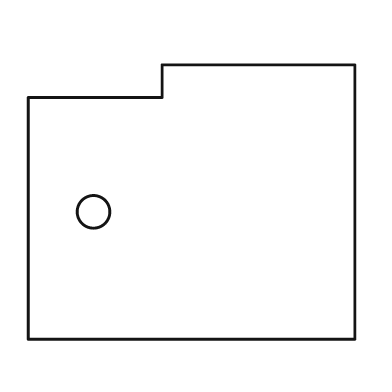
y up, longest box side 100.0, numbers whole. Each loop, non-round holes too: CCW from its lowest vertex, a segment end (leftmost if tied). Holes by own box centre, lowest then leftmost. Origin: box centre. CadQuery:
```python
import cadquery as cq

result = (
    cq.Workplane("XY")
    .moveTo(-50.0, -42.0)
    .lineTo(50.0, -42.0)
    .lineTo(50.0, 42.0)
    .lineTo(-9.0, 42.0)
    .lineTo(-9.0, 32.0)
    .lineTo(-50.0, 32.0)
    .close()
    .moveTo(-30.0, -3.0)
    .circle(5.0)
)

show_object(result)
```